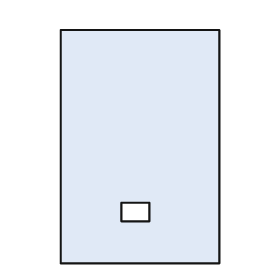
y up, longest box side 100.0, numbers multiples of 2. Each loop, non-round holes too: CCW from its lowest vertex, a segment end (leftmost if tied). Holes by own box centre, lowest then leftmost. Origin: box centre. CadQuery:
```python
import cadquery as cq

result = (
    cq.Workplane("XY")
    .moveTo(-34.0, -50.0)
    .lineTo(34.0, -50.0)
    .lineTo(34.0, 50.0)
    .lineTo(-34.0, 50.0)
    .close()
    .moveTo(-8.0, -32.0)
    .lineTo(4.0, -32.0)
    .lineTo(4.0, -24.0)
    .lineTo(-8.0, -24.0)
    .close()
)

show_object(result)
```